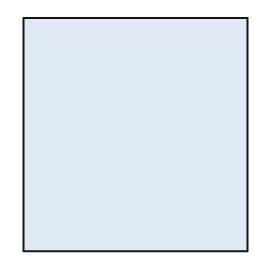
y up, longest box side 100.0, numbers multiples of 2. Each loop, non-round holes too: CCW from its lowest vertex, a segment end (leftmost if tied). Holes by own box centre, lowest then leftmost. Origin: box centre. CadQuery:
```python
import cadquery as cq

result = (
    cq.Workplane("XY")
    .moveTo(-48.0, -50.0)
    .lineTo(48.0, -50.0)
    .lineTo(48.0, 50.0)
    .lineTo(-48.0, 50.0)
    .close()
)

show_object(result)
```